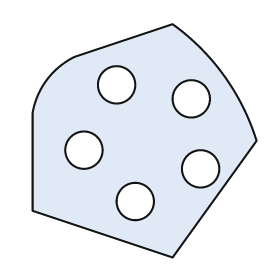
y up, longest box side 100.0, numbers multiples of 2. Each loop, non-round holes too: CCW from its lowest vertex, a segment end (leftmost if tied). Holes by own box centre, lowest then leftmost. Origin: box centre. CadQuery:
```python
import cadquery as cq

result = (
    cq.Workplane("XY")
    .moveTo(12.0, -50.0)
    .lineTo(48.0, 0.0)
    .threePointArc((34.0, 28.0), (12.0, 50.0))
    .lineTo(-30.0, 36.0)
    .threePointArc((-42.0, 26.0), (-48.0, 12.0))
    .lineTo(-48.0, -30.0)
    .close()
    .moveTo(-4.0, -26.0)
    .circle(8.0)
    .moveTo(24.0, -12.0)
    .circle(8.0)
    .moveTo(-26.0, -4.0)
    .circle(8.0)
    .moveTo(20.0, 18.0)
    .circle(8.0)
    .moveTo(-12.0, 24.0)
    .circle(8.0)
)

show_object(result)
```